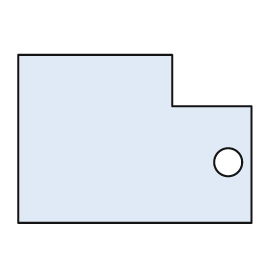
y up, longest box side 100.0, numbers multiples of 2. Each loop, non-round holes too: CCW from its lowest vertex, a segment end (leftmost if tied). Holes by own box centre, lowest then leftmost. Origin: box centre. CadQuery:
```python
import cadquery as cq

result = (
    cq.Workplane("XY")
    .moveTo(-50.0, -36.0)
    .lineTo(50.0, -36.0)
    .lineTo(50.0, 14.0)
    .lineTo(16.0, 14.0)
    .lineTo(16.0, 36.0)
    .lineTo(-50.0, 36.0)
    .close()
    .moveTo(40.0, -10.0)
    .circle(6.0)
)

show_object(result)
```